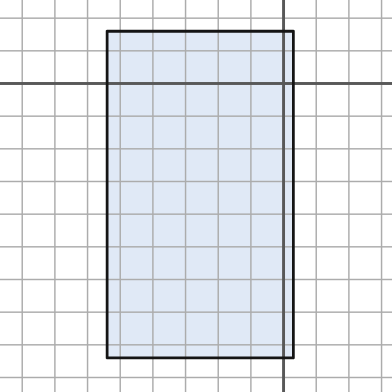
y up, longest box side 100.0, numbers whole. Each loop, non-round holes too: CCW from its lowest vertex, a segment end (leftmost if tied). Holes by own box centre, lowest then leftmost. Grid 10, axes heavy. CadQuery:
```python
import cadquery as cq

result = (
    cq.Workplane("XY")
    .moveTo(-54.0, -84.0)
    .lineTo(3.0, -84.0)
    .lineTo(3.0, 16.0)
    .lineTo(-54.0, 16.0)
    .close()
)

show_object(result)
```